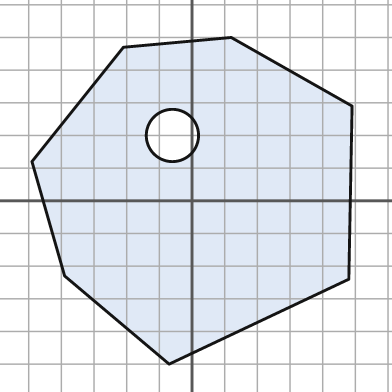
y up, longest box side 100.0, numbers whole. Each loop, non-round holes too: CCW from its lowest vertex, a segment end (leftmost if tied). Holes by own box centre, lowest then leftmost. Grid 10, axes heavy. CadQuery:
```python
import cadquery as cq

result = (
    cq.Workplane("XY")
    .moveTo(-7.0, -50.0)
    .lineTo(48.0, -24.0)
    .lineTo(49.0, 29.0)
    .lineTo(12.0, 50.0)
    .lineTo(-21.0, 47.0)
    .lineTo(-49.0, 12.0)
    .lineTo(-39.0, -23.0)
    .close()
    .moveTo(-6.0, 20.0)
    .circle(8.0)
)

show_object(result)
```